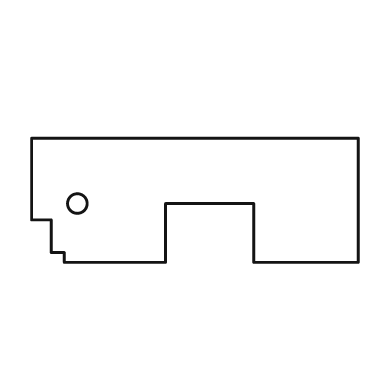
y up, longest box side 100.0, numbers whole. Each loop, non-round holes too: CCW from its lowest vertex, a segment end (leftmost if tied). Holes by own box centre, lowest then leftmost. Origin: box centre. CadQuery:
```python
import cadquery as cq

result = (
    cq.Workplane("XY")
    .moveTo(-40.0, -19.0)
    .lineTo(-9.0, -19.0)
    .lineTo(-9.0, -1.0)
    .lineTo(18.0, -1.0)
    .lineTo(18.0, -19.0)
    .lineTo(50.0, -19.0)
    .lineTo(50.0, 19.0)
    .lineTo(-50.0, 19.0)
    .lineTo(-50.0, -6.0)
    .lineTo(-44.0, -6.0)
    .lineTo(-44.0, -16.0)
    .lineTo(-40.0, -16.0)
    .close()
    .moveTo(-36.0, -1.0)
    .circle(3.0)
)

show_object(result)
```